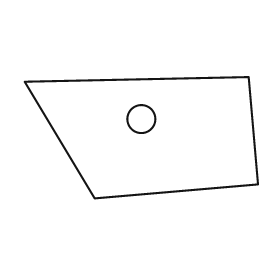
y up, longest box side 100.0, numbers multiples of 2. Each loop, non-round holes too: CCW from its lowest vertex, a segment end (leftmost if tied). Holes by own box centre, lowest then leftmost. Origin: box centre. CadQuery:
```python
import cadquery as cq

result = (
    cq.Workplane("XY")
    .moveTo(-20.0, -26.0)
    .lineTo(50.0, -20.0)
    .lineTo(46.0, 26.0)
    .lineTo(-50.0, 24.0)
    .close()
    .moveTo(0.0, 8.0)
    .circle(6.0)
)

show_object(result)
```